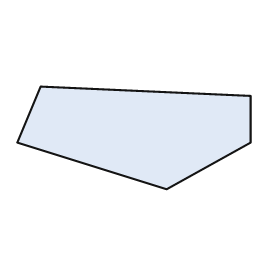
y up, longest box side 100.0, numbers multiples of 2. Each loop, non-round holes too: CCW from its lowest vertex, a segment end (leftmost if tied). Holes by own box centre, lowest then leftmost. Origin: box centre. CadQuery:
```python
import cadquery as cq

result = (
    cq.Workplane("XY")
    .moveTo(14.0, -22.0)
    .lineTo(50.0, -2.0)
    .lineTo(50.0, 18.0)
    .lineTo(-40.0, 22.0)
    .lineTo(-50.0, -2.0)
    .close()
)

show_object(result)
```